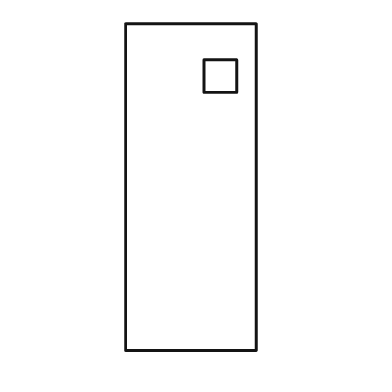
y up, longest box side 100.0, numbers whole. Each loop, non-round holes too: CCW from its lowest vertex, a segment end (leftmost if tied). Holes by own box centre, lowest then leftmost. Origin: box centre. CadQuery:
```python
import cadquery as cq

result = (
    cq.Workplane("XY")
    .moveTo(-20.0, -50.0)
    .lineTo(20.0, -50.0)
    .lineTo(20.0, 50.0)
    .lineTo(-20.0, 50.0)
    .close()
    .moveTo(4.0, 29.0)
    .lineTo(14.0, 29.0)
    .lineTo(14.0, 39.0)
    .lineTo(4.0, 39.0)
    .close()
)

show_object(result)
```